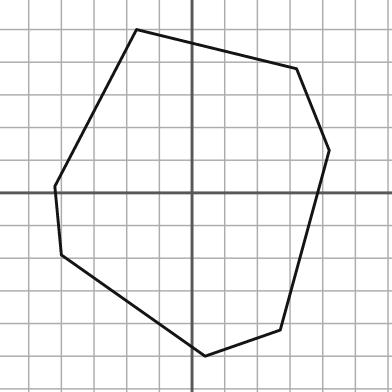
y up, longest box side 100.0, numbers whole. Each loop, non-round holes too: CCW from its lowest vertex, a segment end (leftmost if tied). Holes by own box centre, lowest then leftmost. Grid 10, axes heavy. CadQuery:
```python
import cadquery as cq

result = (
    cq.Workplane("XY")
    .moveTo(4.0, -50.0)
    .lineTo(27.0, -42.0)
    .lineTo(42.0, 13.0)
    .lineTo(32.0, 38.0)
    .lineTo(-17.0, 50.0)
    .lineTo(-42.0, 2.0)
    .lineTo(-40.0, -19.0)
    .close()
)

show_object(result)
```